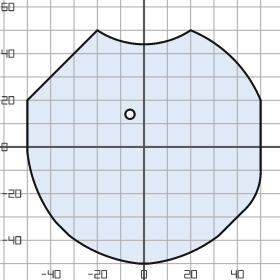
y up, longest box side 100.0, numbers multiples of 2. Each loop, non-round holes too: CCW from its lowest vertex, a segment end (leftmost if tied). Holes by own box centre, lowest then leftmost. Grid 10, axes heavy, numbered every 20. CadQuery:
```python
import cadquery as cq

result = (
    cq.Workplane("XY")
    .moveTo(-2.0, -50.0)
    .lineTo(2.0, -50.0)
    .threePointArc((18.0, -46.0), (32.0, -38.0))
    .lineTo(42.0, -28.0)
    .threePointArc((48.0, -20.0), (50.0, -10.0))
    .lineTo(50.0, 20.0)
    .threePointArc((38.0, 38.0), (20.0, 50.0))
    .threePointArc((0.0, 44.0), (-20.0, 50.0))
    .lineTo(-50.0, 20.0)
    .lineTo(-50.0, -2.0)
    .threePointArc((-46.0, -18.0), (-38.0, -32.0))
    .lineTo(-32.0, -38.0)
    .threePointArc((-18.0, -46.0), (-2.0, -50.0))
    .close()
    .moveTo(-6.0, 14.0)
    .circle(2.0)
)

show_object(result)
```